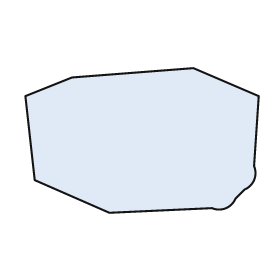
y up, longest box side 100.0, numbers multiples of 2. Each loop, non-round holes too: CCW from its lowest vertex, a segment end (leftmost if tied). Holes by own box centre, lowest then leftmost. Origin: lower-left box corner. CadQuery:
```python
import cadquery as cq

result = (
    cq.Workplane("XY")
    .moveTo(36.0, 0.0)
    .lineTo(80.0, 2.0)
    .threePointArc((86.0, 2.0), (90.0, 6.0))
    .lineTo(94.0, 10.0)
    .threePointArc((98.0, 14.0), (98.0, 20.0))
    .lineTo(100.0, 50.0)
    .lineTo(72.0, 62.0)
    .lineTo(20.0, 58.0)
    .lineTo(0.0, 50.0)
    .lineTo(4.0, 14.0)
    .close()
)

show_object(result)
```